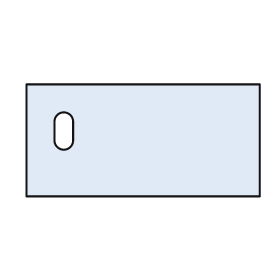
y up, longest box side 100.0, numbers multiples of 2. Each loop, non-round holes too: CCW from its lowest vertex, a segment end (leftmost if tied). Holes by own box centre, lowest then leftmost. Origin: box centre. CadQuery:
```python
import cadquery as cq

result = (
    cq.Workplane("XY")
    .moveTo(-50.0, -24.0)
    .lineTo(50.0, -24.0)
    .lineTo(50.0, 24.0)
    .lineTo(-50.0, 24.0)
    .close()
    .moveTo(-38.0, 0.0)
    .threePointArc((-34.0, -4.0), (-30.0, 0.0))
    .lineTo(-30.0, 8.0)
    .threePointArc((-34.0, 12.0), (-38.0, 8.0))
    .close()
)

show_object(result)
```